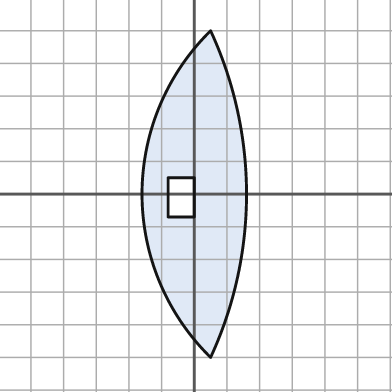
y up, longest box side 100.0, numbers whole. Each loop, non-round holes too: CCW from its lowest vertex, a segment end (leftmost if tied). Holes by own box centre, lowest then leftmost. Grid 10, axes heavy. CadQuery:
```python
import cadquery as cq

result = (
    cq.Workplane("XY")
    .moveTo(5.0, -50.0)
    .threePointArc((16.0, 0.0), (5.0, 50.0))
    .threePointArc((-16.0, 0.0), (5.0, -50.0))
    .close()
    .moveTo(-8.0, -7.0)
    .lineTo(0.0, -7.0)
    .lineTo(0.0, 5.0)
    .lineTo(-8.0, 5.0)
    .close()
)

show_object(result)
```